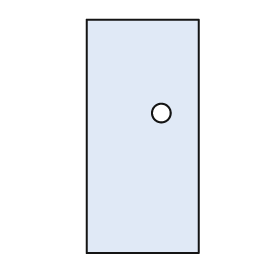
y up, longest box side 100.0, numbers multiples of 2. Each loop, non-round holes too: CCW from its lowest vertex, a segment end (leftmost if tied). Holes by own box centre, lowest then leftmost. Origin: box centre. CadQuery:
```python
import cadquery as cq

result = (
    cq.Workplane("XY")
    .moveTo(-24.0, -50.0)
    .lineTo(24.0, -50.0)
    .lineTo(24.0, 50.0)
    .lineTo(-24.0, 50.0)
    .close()
    .moveTo(8.0, 10.0)
    .circle(4.0)
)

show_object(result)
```